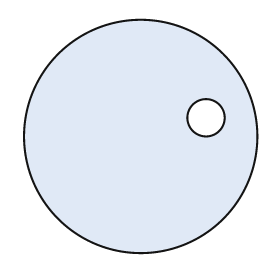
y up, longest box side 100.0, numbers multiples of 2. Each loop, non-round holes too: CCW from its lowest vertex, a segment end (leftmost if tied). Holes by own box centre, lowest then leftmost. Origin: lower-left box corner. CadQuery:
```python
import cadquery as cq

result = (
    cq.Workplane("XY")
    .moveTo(50.0, 50.0)
    .circle(50.0)
    .moveTo(78.0, 58.0)
    .circle(8.0)
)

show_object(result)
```